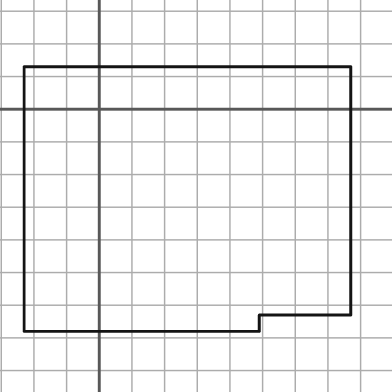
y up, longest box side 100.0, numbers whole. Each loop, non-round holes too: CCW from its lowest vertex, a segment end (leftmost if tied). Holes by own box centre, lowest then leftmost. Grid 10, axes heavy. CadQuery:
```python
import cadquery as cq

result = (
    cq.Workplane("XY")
    .moveTo(-23.0, -68.0)
    .lineTo(49.0, -68.0)
    .lineTo(49.0, -63.0)
    .lineTo(77.0, -63.0)
    .lineTo(77.0, 13.0)
    .lineTo(-23.0, 13.0)
    .close()
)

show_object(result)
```